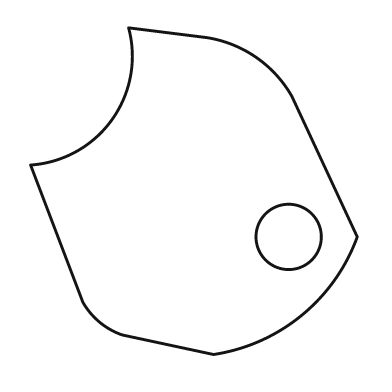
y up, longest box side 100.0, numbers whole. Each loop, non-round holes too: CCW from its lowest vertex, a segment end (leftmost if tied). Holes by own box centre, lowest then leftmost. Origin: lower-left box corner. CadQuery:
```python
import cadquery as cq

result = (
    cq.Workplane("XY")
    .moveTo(56.0, 0.0)
    .threePointArc((83.0, 12.0), (100.0, 36.0))
    .lineTo(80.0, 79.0)
    .threePointArc((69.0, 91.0), (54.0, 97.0))
    .lineTo(30.0, 100.0)
    .threePointArc((25.0, 72.0), (0.0, 58.0))
    .lineTo(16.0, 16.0)
    .threePointArc((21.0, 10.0), (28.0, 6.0))
    .close()
    .moveTo(79.0, 36.0)
    .circle(10.0)
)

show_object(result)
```